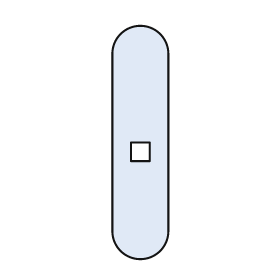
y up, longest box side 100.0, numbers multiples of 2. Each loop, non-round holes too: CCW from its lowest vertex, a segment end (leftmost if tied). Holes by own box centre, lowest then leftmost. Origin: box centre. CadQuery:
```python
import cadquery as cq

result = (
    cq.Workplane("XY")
    .moveTo(-12.0, -38.0)
    .threePointArc((0.0, -50.0), (12.0, -38.0))
    .lineTo(12.0, 38.0)
    .threePointArc((0.0, 50.0), (-12.0, 38.0))
    .close()
    .moveTo(-4.0, -8.0)
    .lineTo(4.0, -8.0)
    .lineTo(4.0, 0.0)
    .lineTo(-4.0, 0.0)
    .close()
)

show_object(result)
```